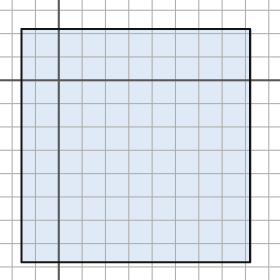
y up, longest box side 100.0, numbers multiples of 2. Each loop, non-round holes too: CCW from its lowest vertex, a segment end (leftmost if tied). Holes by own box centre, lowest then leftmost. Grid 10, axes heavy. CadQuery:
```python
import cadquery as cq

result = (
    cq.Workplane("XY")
    .moveTo(-16.0, -78.0)
    .lineTo(82.0, -78.0)
    .lineTo(82.0, 22.0)
    .lineTo(-16.0, 22.0)
    .close()
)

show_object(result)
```